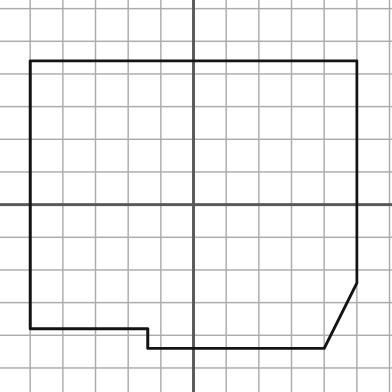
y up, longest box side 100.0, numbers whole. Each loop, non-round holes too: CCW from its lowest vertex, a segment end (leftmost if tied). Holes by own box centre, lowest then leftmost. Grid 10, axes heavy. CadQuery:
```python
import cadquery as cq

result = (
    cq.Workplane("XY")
    .moveTo(-14.0, -44.0)
    .lineTo(40.0, -44.0)
    .lineTo(50.0, -24.0)
    .lineTo(50.0, 44.0)
    .lineTo(-50.0, 44.0)
    .lineTo(-50.0, -38.0)
    .lineTo(-14.0, -38.0)
    .close()
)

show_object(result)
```